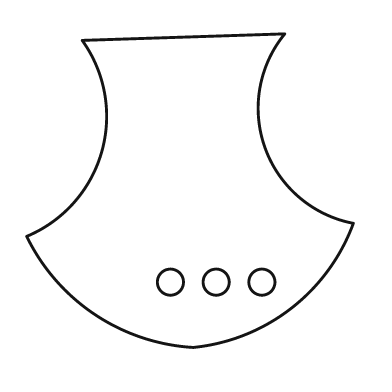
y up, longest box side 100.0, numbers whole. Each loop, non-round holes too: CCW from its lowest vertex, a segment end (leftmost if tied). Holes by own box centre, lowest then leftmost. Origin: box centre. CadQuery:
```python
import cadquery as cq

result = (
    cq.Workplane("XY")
    .moveTo(1.0, -48.0)
    .threePointArc((31.0, -36.0), (50.0, -10.0))
    .threePointArc((23.0, 13.0), (29.0, 48.0))
    .lineTo(-33.0, 46.0)
    .threePointArc((-27.0, 12.0), (-50.0, -14.0))
    .threePointArc((-29.0, -38.0), (1.0, -48.0))
    .close()
    .moveTo(-6.0, -28.0)
    .circle(4.0)
    .moveTo(8.0, -28.0)
    .circle(4.0)
    .moveTo(22.0, -28.0)
    .circle(4.0)
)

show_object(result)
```